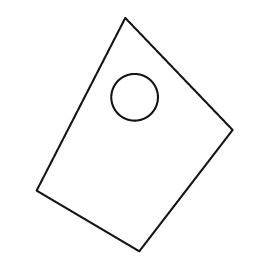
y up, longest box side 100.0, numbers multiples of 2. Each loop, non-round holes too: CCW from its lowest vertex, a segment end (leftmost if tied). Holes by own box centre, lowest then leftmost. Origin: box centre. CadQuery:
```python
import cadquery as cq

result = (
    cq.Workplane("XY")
    .moveTo(2.0, -50.0)
    .lineTo(42.0, 2.0)
    .lineTo(-4.0, 50.0)
    .lineTo(-42.0, -24.0)
    .close()
    .moveTo(0.0, 16.0)
    .circle(10.0)
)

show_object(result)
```